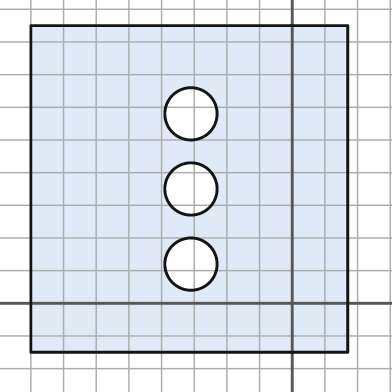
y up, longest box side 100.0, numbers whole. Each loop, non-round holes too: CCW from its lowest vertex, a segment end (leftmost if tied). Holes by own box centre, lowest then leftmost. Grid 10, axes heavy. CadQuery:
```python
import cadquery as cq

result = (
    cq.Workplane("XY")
    .moveTo(-80.0, -15.0)
    .lineTo(17.0, -15.0)
    .lineTo(17.0, 85.0)
    .lineTo(-80.0, 85.0)
    .close()
    .moveTo(-31.0, 12.0)
    .circle(8.0)
    .moveTo(-31.0, 35.0)
    .circle(8.0)
    .moveTo(-31.0, 58.0)
    .circle(8.0)
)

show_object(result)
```